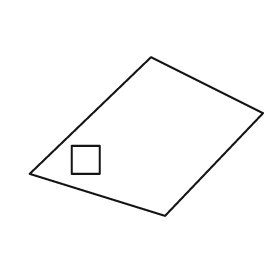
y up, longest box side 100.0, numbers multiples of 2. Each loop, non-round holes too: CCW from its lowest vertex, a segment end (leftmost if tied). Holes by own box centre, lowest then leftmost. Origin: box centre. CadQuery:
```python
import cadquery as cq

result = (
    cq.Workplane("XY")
    .moveTo(8.0, -34.0)
    .lineTo(50.0, 10.0)
    .lineTo(2.0, 34.0)
    .lineTo(-50.0, -16.0)
    .close()
    .moveTo(-32.0, -16.0)
    .lineTo(-20.0, -16.0)
    .lineTo(-20.0, -4.0)
    .lineTo(-32.0, -4.0)
    .close()
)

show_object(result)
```